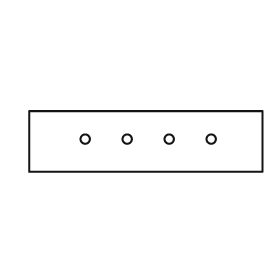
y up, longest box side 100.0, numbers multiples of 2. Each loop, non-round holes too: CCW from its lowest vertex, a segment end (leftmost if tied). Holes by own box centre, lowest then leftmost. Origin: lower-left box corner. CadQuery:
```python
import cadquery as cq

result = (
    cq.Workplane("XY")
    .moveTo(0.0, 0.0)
    .lineTo(100.0, 0.0)
    .lineTo(100.0, 26.0)
    .lineTo(0.0, 26.0)
    .close()
    .moveTo(24.0, 14.0)
    .circle(2.0)
    .moveTo(42.0, 14.0)
    .circle(2.0)
    .moveTo(60.0, 14.0)
    .circle(2.0)
    .moveTo(78.0, 14.0)
    .circle(2.0)
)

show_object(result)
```